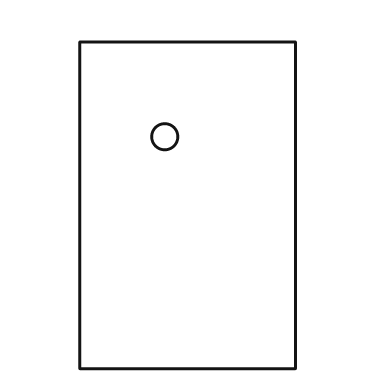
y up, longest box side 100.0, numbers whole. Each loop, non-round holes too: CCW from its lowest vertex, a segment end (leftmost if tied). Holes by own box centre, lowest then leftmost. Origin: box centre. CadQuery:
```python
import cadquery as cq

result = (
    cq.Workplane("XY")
    .moveTo(-33.0, -50.0)
    .lineTo(33.0, -50.0)
    .lineTo(33.0, 50.0)
    .lineTo(-33.0, 50.0)
    .close()
    .moveTo(-7.0, 21.0)
    .circle(4.0)
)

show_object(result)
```